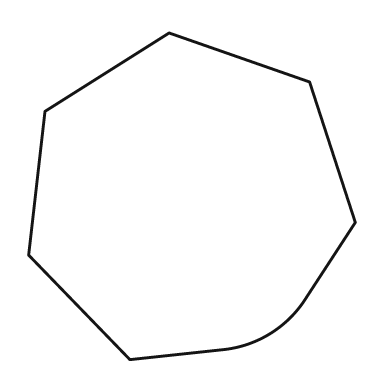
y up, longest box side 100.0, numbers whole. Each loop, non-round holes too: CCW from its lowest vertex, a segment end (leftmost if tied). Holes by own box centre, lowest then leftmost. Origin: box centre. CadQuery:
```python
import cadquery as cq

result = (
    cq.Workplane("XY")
    .moveTo(-19.0, -50.0)
    .lineTo(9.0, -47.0)
    .threePointArc((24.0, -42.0), (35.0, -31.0))
    .lineTo(50.0, -8.0)
    .lineTo(36.0, 35.0)
    .lineTo(-7.0, 50.0)
    .lineTo(-45.0, 26.0)
    .lineTo(-50.0, -18.0)
    .close()
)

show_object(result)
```